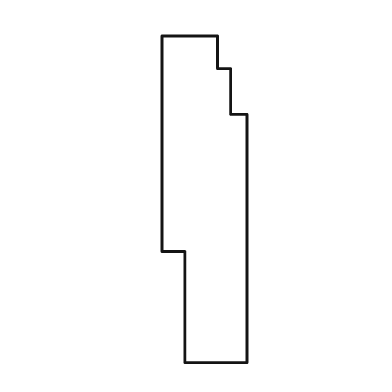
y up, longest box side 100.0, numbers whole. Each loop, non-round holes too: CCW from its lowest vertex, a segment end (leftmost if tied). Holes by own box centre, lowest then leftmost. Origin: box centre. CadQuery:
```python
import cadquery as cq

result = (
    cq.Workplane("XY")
    .moveTo(-6.0, -50.0)
    .lineTo(13.0, -50.0)
    .lineTo(13.0, 26.0)
    .lineTo(8.0, 26.0)
    .lineTo(8.0, 40.0)
    .lineTo(4.0, 40.0)
    .lineTo(4.0, 50.0)
    .lineTo(-13.0, 50.0)
    .lineTo(-13.0, -16.0)
    .lineTo(-6.0, -16.0)
    .close()
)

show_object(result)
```